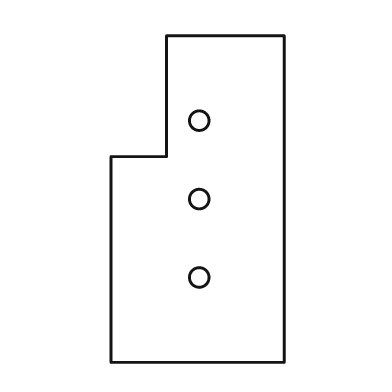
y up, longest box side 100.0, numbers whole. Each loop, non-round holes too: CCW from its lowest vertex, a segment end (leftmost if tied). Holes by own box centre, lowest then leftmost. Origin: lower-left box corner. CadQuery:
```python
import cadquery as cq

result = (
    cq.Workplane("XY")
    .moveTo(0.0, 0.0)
    .lineTo(53.0, 0.0)
    .lineTo(53.0, 100.0)
    .lineTo(17.0, 100.0)
    .lineTo(17.0, 63.0)
    .lineTo(0.0, 63.0)
    .close()
    .moveTo(27.0, 26.0)
    .circle(3.0)
    .moveTo(27.0, 50.0)
    .circle(3.0)
    .moveTo(27.0, 74.0)
    .circle(3.0)
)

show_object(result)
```